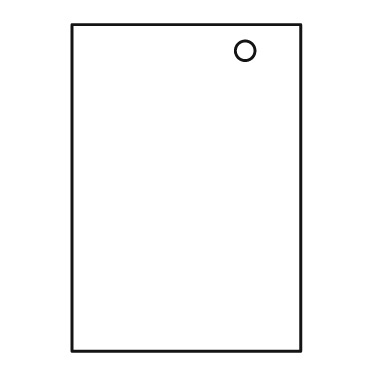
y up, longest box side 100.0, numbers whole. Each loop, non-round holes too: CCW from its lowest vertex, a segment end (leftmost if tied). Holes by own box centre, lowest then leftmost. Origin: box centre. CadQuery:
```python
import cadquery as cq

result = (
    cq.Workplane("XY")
    .moveTo(-35.0, -50.0)
    .lineTo(35.0, -50.0)
    .lineTo(35.0, 50.0)
    .lineTo(-35.0, 50.0)
    .close()
    .moveTo(18.0, 42.0)
    .circle(3.0)
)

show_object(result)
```